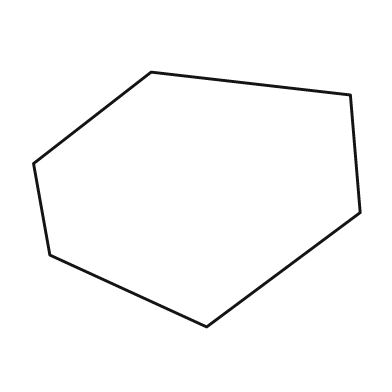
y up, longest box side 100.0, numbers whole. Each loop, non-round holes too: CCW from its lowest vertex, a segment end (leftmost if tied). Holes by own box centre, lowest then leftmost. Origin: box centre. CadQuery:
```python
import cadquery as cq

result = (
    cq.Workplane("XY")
    .moveTo(3.0, -39.0)
    .lineTo(50.0, -4.0)
    .lineTo(47.0, 32.0)
    .lineTo(-14.0, 39.0)
    .lineTo(-50.0, 11.0)
    .lineTo(-45.0, -17.0)
    .close()
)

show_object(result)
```